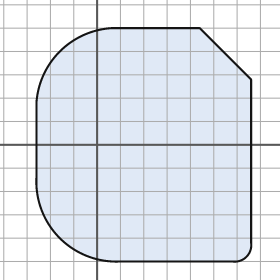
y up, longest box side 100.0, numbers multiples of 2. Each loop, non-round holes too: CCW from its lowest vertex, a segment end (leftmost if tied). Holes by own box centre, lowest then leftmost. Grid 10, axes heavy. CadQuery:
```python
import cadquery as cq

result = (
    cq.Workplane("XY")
    .moveTo(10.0, -50.0)
    .lineTo(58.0, -50.0)
    .threePointArc((64.0, -48.0), (66.0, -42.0))
    .lineTo(66.0, 28.0)
    .lineTo(44.0, 50.0)
    .lineTo(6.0, 50.0)
    .threePointArc((-16.0, 40.0), (-26.0, 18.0))
    .lineTo(-26.0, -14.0)
    .threePointArc((-16.0, -40.0), (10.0, -50.0))
    .close()
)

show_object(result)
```